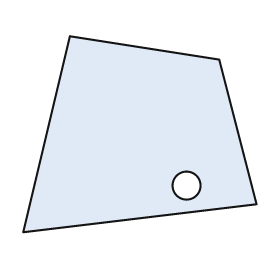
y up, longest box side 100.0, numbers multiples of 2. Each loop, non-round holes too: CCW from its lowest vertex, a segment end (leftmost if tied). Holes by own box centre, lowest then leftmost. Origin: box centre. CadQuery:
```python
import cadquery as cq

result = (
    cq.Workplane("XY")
    .moveTo(-50.0, -42.0)
    .lineTo(50.0, -30.0)
    .lineTo(34.0, 32.0)
    .lineTo(-30.0, 42.0)
    .close()
    .moveTo(20.0, -22.0)
    .circle(6.0)
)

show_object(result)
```